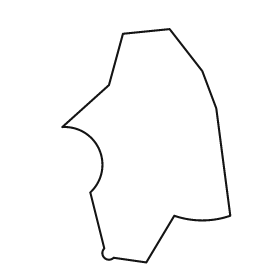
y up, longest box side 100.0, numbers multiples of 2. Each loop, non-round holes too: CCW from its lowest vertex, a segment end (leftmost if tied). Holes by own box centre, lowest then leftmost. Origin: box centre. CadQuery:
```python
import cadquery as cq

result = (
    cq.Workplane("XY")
    .moveTo(0.0, -50.0)
    .lineTo(12.0, -30.0)
    .threePointArc((24.0, -32.0), (36.0, -30.0))
    .lineTo(30.0, 16.0)
    .lineTo(24.0, 32.0)
    .lineTo(10.0, 50.0)
    .lineTo(-10.0, 48.0)
    .lineTo(-16.0, 26.0)
    .lineTo(-36.0, 8.0)
    .threePointArc((-20.0, -2.0), (-24.0, -20.0))
    .lineTo(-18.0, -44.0)
    .threePointArc((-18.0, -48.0), (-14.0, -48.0))
    .close()
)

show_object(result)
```